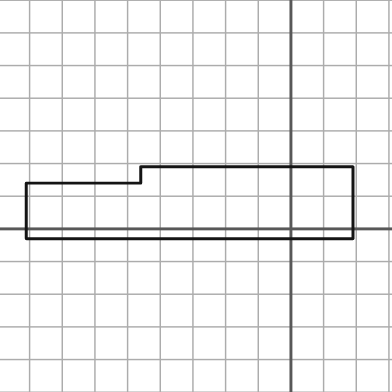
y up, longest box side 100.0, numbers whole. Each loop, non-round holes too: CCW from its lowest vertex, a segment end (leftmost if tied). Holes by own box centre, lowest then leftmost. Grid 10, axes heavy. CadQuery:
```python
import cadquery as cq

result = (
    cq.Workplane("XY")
    .moveTo(-81.0, -3.0)
    .lineTo(19.0, -3.0)
    .lineTo(19.0, 19.0)
    .lineTo(-46.0, 19.0)
    .lineTo(-46.0, 14.0)
    .lineTo(-81.0, 14.0)
    .close()
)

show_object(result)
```